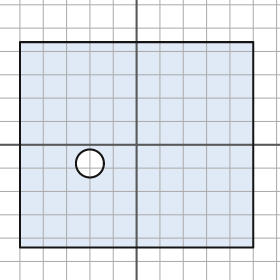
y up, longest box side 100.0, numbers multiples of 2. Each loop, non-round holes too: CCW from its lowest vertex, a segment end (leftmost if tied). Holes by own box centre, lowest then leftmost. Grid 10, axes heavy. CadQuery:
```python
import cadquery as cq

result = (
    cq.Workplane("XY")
    .moveTo(-50.0, -44.0)
    .lineTo(50.0, -44.0)
    .lineTo(50.0, 44.0)
    .lineTo(-50.0, 44.0)
    .close()
    .moveTo(-20.0, -8.0)
    .circle(6.0)
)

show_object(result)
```